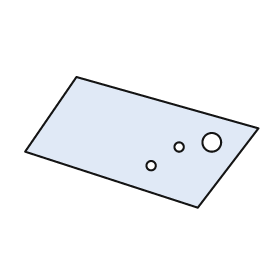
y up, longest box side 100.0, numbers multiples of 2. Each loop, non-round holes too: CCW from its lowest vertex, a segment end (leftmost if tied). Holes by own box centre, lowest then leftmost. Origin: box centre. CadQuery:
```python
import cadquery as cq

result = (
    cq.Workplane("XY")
    .moveTo(24.0, -28.0)
    .lineTo(50.0, 6.0)
    .lineTo(-28.0, 28.0)
    .lineTo(-50.0, -4.0)
    .close()
    .moveTo(4.0, -10.0)
    .circle(2.0)
    .moveTo(16.0, -2.0)
    .circle(2.0)
    .moveTo(30.0, 0.0)
    .circle(4.0)
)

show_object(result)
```